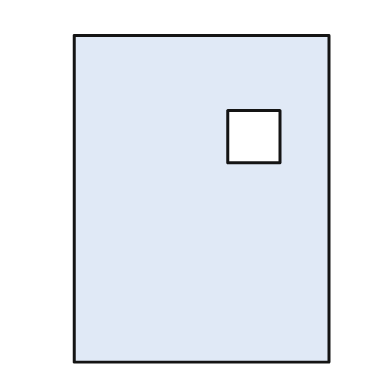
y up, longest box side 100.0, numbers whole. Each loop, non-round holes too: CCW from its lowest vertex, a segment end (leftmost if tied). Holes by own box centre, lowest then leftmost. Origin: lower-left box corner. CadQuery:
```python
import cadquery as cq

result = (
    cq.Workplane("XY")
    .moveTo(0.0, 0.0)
    .lineTo(78.0, 0.0)
    .lineTo(78.0, 100.0)
    .lineTo(0.0, 100.0)
    .close()
    .moveTo(47.0, 61.0)
    .lineTo(63.0, 61.0)
    .lineTo(63.0, 77.0)
    .lineTo(47.0, 77.0)
    .close()
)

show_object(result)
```